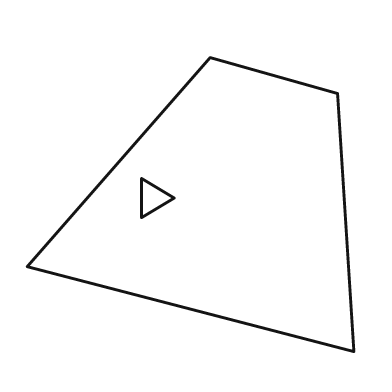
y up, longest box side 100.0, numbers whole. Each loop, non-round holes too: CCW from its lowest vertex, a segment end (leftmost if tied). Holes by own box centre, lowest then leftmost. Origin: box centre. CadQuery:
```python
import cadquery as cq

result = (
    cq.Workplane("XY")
    .moveTo(50.0, -45.0)
    .lineTo(45.0, 34.0)
    .lineTo(6.0, 45.0)
    .lineTo(-50.0, -19.0)
    .close()
    .moveTo(-15.0, -4.0)
    .lineTo(-5.0, 2.0)
    .lineTo(-15.0, 8.0)
    .close()
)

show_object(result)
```